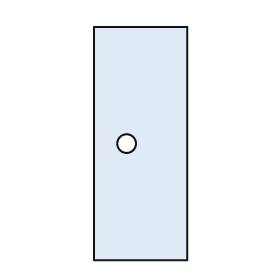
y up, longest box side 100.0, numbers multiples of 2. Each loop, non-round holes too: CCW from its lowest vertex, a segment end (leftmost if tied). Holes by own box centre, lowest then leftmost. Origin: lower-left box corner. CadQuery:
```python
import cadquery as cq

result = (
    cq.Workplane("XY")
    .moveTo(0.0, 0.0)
    .lineTo(40.0, 0.0)
    .lineTo(40.0, 100.0)
    .lineTo(0.0, 100.0)
    .close()
    .moveTo(14.0, 50.0)
    .circle(4.0)
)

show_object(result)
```